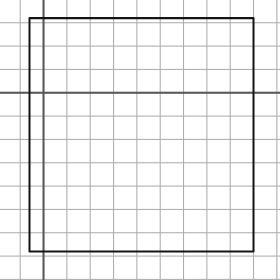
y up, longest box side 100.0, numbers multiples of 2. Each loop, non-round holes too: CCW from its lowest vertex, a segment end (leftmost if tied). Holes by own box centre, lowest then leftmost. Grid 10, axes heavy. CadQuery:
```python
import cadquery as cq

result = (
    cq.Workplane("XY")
    .moveTo(-6.0, -68.0)
    .lineTo(90.0, -68.0)
    .lineTo(90.0, 32.0)
    .lineTo(-6.0, 32.0)
    .close()
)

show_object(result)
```